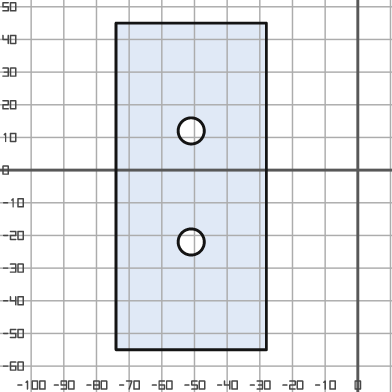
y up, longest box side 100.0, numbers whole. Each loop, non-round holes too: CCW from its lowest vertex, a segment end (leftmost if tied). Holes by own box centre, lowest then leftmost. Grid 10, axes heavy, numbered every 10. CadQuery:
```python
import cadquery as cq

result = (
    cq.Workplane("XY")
    .moveTo(-74.0, -55.0)
    .lineTo(-28.0, -55.0)
    .lineTo(-28.0, 45.0)
    .lineTo(-74.0, 45.0)
    .close()
    .moveTo(-51.0, -22.0)
    .circle(4.0)
    .moveTo(-51.0, 12.0)
    .circle(4.0)
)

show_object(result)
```